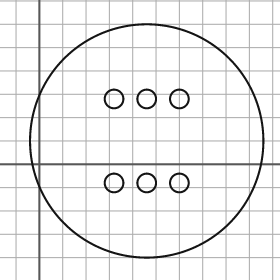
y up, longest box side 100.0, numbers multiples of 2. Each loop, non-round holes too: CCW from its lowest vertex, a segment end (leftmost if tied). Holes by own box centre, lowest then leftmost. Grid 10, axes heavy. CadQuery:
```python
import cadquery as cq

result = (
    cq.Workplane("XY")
    .moveTo(46.0, 10.0)
    .circle(50.0)
    .moveTo(32.0, -8.0)
    .circle(4.0)
    .moveTo(46.0, -8.0)
    .circle(4.0)
    .moveTo(60.0, -8.0)
    .circle(4.0)
    .moveTo(32.0, 28.0)
    .circle(4.0)
    .moveTo(46.0, 28.0)
    .circle(4.0)
    .moveTo(60.0, 28.0)
    .circle(4.0)
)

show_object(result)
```